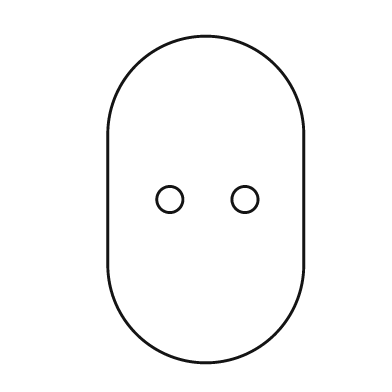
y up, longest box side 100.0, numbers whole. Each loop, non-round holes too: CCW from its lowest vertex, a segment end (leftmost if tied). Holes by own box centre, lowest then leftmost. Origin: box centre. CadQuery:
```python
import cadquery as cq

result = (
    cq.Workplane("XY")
    .moveTo(-30.0, -20.0)
    .threePointArc((0.0, -50.0), (30.0, -20.0))
    .lineTo(30.0, 20.0)
    .threePointArc((0.0, 50.0), (-30.0, 20.0))
    .close()
    .moveTo(-11.0, 0.0)
    .circle(4.0)
    .moveTo(12.0, 0.0)
    .circle(4.0)
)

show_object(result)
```